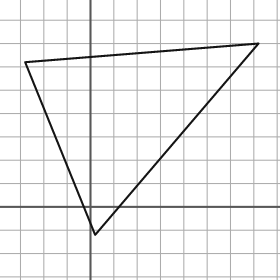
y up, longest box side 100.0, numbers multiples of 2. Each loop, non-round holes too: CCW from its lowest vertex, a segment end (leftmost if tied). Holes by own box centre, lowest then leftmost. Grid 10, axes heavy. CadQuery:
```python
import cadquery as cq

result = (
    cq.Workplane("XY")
    .moveTo(2.0, -12.0)
    .lineTo(72.0, 70.0)
    .lineTo(-28.0, 62.0)
    .close()
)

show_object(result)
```